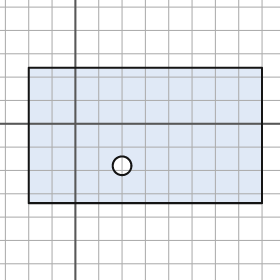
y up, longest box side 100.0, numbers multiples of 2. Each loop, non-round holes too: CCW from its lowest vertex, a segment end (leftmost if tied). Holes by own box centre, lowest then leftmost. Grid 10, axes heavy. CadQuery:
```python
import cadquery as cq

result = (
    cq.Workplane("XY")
    .moveTo(-20.0, -34.0)
    .lineTo(80.0, -34.0)
    .lineTo(80.0, 24.0)
    .lineTo(-20.0, 24.0)
    .close()
    .moveTo(20.0, -18.0)
    .circle(4.0)
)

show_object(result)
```